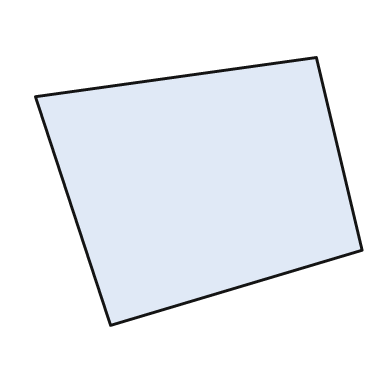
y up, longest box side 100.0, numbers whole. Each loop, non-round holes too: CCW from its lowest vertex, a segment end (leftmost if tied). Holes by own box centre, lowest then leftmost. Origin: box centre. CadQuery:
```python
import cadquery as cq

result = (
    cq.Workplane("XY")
    .moveTo(-27.0, -41.0)
    .lineTo(50.0, -18.0)
    .lineTo(36.0, 41.0)
    .lineTo(-50.0, 29.0)
    .close()
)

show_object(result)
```